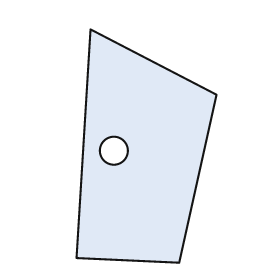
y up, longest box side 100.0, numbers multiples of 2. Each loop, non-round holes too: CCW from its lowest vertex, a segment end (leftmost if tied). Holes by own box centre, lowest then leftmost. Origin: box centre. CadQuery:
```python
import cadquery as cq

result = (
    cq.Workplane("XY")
    .moveTo(14.0, -50.0)
    .lineTo(30.0, 22.0)
    .lineTo(-24.0, 50.0)
    .lineTo(-30.0, -48.0)
    .close()
    .moveTo(-14.0, -2.0)
    .circle(6.0)
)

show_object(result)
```